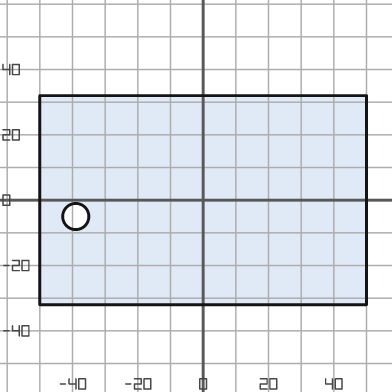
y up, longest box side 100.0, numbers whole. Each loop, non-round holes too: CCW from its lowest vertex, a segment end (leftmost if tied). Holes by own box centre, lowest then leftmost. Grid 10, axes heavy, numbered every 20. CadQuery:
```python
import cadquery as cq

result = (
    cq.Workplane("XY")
    .moveTo(-50.0, -32.0)
    .lineTo(50.0, -32.0)
    .lineTo(50.0, 32.0)
    .lineTo(-50.0, 32.0)
    .close()
    .moveTo(-39.0, -5.0)
    .circle(4.0)
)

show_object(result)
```